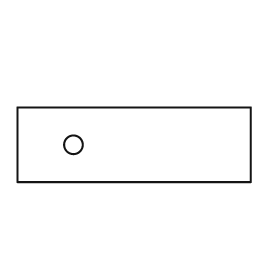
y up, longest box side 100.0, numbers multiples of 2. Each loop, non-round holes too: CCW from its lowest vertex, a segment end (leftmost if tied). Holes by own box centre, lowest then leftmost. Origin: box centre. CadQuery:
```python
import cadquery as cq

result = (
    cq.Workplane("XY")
    .moveTo(-50.0, -16.0)
    .lineTo(50.0, -16.0)
    .lineTo(50.0, 16.0)
    .lineTo(-50.0, 16.0)
    .close()
    .moveTo(-26.0, 0.0)
    .circle(4.0)
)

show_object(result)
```